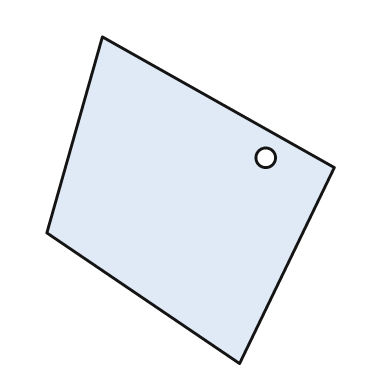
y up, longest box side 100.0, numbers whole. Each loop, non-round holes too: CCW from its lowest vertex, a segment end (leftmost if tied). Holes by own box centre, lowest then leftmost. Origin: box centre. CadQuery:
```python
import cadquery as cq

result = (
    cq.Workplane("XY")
    .moveTo(15.0, -50.0)
    .lineTo(44.0, 10.0)
    .lineTo(-27.0, 50.0)
    .lineTo(-44.0, -10.0)
    .close()
    .moveTo(23.0, 13.0)
    .circle(3.0)
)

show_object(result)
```